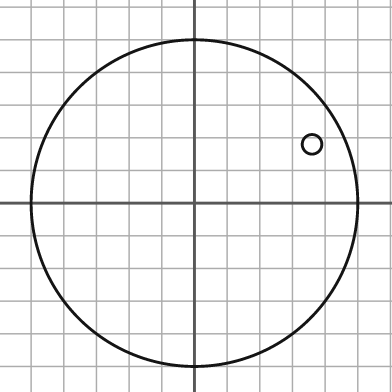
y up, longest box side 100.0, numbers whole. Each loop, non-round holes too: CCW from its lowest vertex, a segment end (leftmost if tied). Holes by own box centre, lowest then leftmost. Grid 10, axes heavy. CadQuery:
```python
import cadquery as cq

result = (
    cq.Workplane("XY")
    .moveTo(0.0, 0.0)
    .circle(50.0)
    .moveTo(36.0, 18.0)
    .circle(3.0)
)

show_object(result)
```